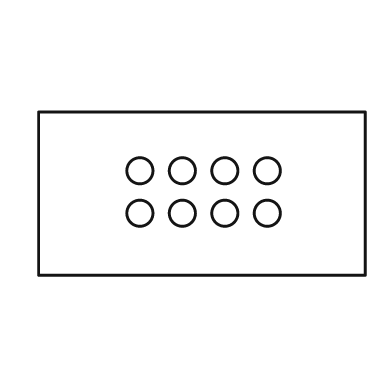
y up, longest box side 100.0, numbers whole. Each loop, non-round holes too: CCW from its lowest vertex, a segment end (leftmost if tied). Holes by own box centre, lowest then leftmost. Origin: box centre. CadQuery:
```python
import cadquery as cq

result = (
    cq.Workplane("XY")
    .moveTo(-50.0, -25.0)
    .lineTo(50.0, -25.0)
    .lineTo(50.0, 25.0)
    .lineTo(-50.0, 25.0)
    .close()
    .moveTo(-19.0, -6.0)
    .circle(4.0)
    .moveTo(-6.0, -6.0)
    .circle(4.0)
    .moveTo(7.0, -6.0)
    .circle(4.0)
    .moveTo(20.0, -6.0)
    .circle(4.0)
    .moveTo(-19.0, 7.0)
    .circle(4.0)
    .moveTo(-6.0, 7.0)
    .circle(4.0)
    .moveTo(7.0, 7.0)
    .circle(4.0)
    .moveTo(20.0, 7.0)
    .circle(4.0)
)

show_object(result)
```